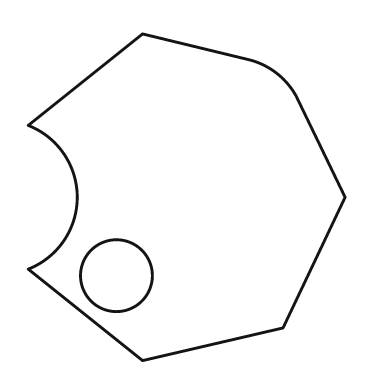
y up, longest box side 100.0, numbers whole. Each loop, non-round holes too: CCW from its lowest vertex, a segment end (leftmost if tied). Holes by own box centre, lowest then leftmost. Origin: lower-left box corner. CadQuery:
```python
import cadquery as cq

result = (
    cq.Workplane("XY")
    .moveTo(35.0, 0.0)
    .lineTo(78.0, 10.0)
    .lineTo(97.0, 50.0)
    .lineTo(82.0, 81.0)
    .threePointArc((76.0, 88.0), (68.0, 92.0))
    .lineTo(35.0, 100.0)
    .lineTo(0.0, 72.0)
    .threePointArc((15.0, 50.0), (0.0, 28.0))
    .close()
    .moveTo(27.0, 26.0)
    .circle(11.0)
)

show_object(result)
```